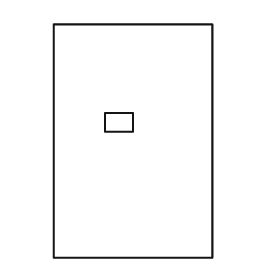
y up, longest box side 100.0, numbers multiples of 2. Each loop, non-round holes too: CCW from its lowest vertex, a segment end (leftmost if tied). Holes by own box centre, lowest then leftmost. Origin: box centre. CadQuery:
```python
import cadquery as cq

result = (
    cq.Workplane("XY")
    .moveTo(-34.0, -50.0)
    .lineTo(34.0, -50.0)
    .lineTo(34.0, 50.0)
    .lineTo(-34.0, 50.0)
    .close()
    .moveTo(-12.0, 4.0)
    .lineTo(0.0, 4.0)
    .lineTo(0.0, 12.0)
    .lineTo(-12.0, 12.0)
    .close()
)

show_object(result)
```